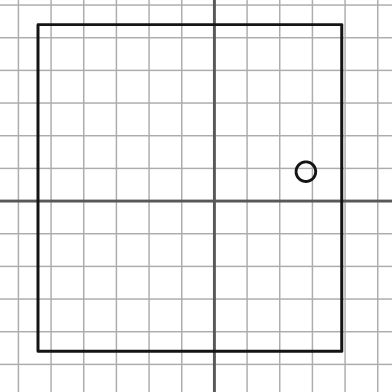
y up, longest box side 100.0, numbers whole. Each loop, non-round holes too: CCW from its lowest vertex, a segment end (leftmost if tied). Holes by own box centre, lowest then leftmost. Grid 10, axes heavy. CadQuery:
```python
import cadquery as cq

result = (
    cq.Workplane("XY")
    .moveTo(-54.0, -46.0)
    .lineTo(39.0, -46.0)
    .lineTo(39.0, 54.0)
    .lineTo(-54.0, 54.0)
    .close()
    .moveTo(28.0, 9.0)
    .circle(3.0)
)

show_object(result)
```